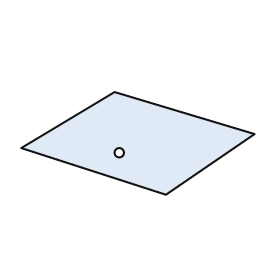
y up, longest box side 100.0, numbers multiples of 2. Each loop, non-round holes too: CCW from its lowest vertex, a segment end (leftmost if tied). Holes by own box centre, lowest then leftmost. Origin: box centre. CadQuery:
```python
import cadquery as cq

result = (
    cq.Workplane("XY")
    .moveTo(12.0, -22.0)
    .lineTo(50.0, 4.0)
    .lineTo(-10.0, 22.0)
    .lineTo(-50.0, -2.0)
    .close()
    .moveTo(-8.0, -4.0)
    .circle(2.0)
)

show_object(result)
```